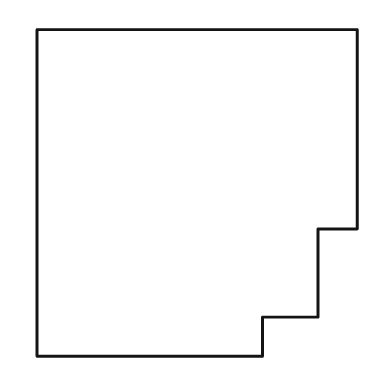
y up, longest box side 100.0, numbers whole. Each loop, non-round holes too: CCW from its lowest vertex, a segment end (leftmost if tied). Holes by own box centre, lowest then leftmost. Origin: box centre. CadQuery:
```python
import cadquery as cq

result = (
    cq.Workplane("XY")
    .moveTo(-49.0, -50.0)
    .lineTo(20.0, -50.0)
    .lineTo(20.0, -38.0)
    .lineTo(37.0, -38.0)
    .lineTo(37.0, -11.0)
    .lineTo(49.0, -11.0)
    .lineTo(49.0, 50.0)
    .lineTo(-49.0, 50.0)
    .close()
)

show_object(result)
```